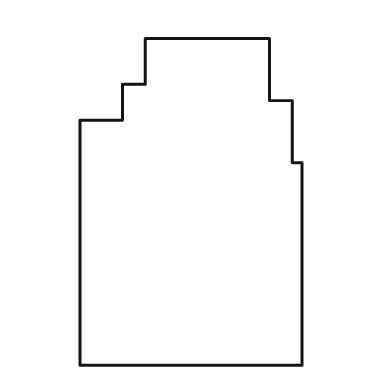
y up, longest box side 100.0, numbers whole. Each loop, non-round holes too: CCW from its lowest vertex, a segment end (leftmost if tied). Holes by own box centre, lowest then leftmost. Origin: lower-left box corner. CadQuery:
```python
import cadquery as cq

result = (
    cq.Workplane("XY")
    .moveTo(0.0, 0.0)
    .lineTo(68.0, 0.0)
    .lineTo(68.0, 62.0)
    .lineTo(65.0, 62.0)
    .lineTo(65.0, 81.0)
    .lineTo(58.0, 81.0)
    .lineTo(58.0, 100.0)
    .lineTo(20.0, 100.0)
    .lineTo(20.0, 86.0)
    .lineTo(13.0, 86.0)
    .lineTo(13.0, 75.0)
    .lineTo(0.0, 75.0)
    .close()
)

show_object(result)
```